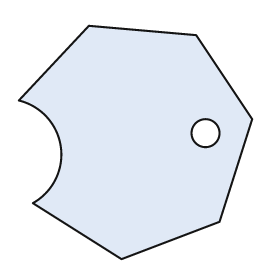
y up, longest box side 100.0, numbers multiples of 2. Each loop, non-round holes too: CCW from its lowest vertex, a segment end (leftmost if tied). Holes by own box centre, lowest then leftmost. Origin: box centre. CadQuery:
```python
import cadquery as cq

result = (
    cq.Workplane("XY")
    .moveTo(-6.0, -50.0)
    .lineTo(36.0, -34.0)
    .lineTo(50.0, 10.0)
    .lineTo(26.0, 46.0)
    .lineTo(-20.0, 50.0)
    .lineTo(-50.0, 18.0)
    .threePointArc((-32.0, -2.0), (-44.0, -26.0))
    .close()
    .moveTo(30.0, 4.0)
    .circle(6.0)
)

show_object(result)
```